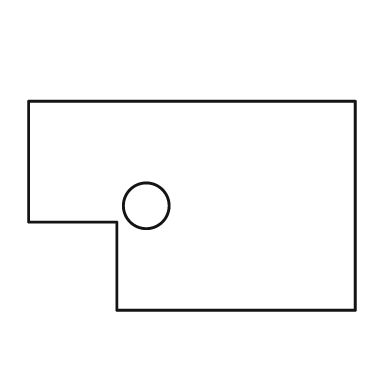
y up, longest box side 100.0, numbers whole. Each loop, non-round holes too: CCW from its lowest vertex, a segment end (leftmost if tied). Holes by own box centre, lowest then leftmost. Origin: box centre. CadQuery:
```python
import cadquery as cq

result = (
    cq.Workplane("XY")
    .moveTo(-23.0, -32.0)
    .lineTo(50.0, -32.0)
    .lineTo(50.0, 32.0)
    .lineTo(-50.0, 32.0)
    .lineTo(-50.0, -5.0)
    .lineTo(-23.0, -5.0)
    .close()
    .moveTo(-14.0, 0.0)
    .circle(7.0)
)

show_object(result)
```